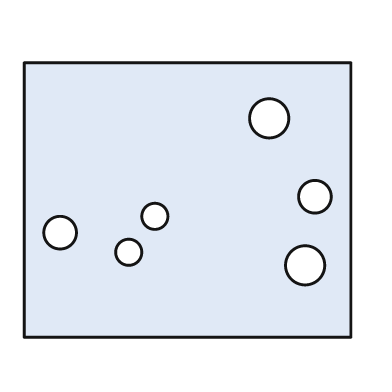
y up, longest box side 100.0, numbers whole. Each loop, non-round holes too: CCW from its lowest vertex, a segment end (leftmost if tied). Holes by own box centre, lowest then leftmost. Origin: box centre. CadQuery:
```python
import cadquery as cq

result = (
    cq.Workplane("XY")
    .moveTo(-50.0, -42.0)
    .lineTo(50.0, -42.0)
    .lineTo(50.0, 42.0)
    .lineTo(-50.0, 42.0)
    .close()
    .moveTo(36.0, -20.0)
    .circle(6.0)
    .moveTo(-18.0, -16.0)
    .circle(4.0)
    .moveTo(-39.0, -10.0)
    .circle(5.0)
    .moveTo(-10.0, -5.0)
    .circle(4.0)
    .moveTo(39.0, 1.0)
    .circle(5.0)
    .moveTo(25.0, 25.0)
    .circle(6.0)
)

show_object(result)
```